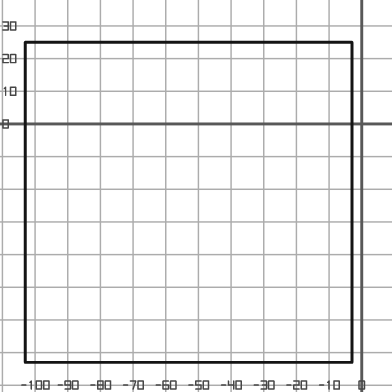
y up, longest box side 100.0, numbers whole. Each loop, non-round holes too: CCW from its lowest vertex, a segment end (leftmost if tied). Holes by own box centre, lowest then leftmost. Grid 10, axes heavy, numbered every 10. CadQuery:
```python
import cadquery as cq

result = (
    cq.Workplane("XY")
    .moveTo(-103.0, -73.0)
    .lineTo(-3.0, -73.0)
    .lineTo(-3.0, 25.0)
    .lineTo(-103.0, 25.0)
    .close()
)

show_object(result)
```